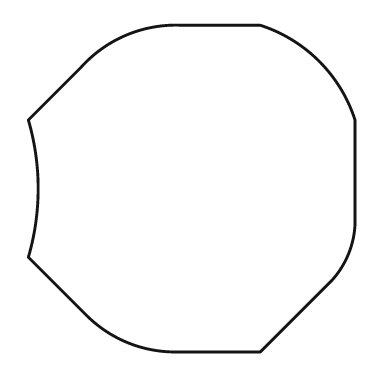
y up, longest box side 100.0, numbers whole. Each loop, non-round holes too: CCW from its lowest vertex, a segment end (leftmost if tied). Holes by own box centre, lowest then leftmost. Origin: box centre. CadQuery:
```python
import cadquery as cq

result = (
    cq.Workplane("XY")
    .moveTo(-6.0, -50.0)
    .lineTo(21.0, -50.0)
    .lineTo(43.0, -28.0)
    .threePointArc((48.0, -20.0), (50.0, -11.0))
    .lineTo(50.0, 21.0)
    .threePointArc((39.0, 39.0), (21.0, 50.0))
    .lineTo(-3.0, 50.0)
    .threePointArc((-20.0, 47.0), (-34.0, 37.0))
    .lineTo(-50.0, 21.0)
    .threePointArc((-47.0, 0.0), (-50.0, -21.0))
    .lineTo(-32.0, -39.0)
    .threePointArc((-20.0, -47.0), (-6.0, -50.0))
    .close()
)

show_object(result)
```